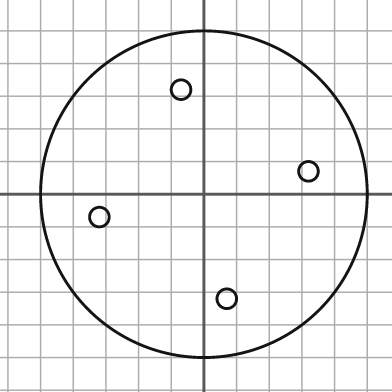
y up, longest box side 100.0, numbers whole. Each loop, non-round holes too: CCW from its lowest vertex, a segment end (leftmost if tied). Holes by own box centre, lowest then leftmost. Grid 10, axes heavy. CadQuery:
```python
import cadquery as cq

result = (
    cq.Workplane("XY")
    .moveTo(0.0, 0.0)
    .circle(50.0)
    .moveTo(7.0, -32.0)
    .circle(3.0)
    .moveTo(-32.0, -7.0)
    .circle(3.0)
    .moveTo(32.0, 7.0)
    .circle(3.0)
    .moveTo(-7.0, 32.0)
    .circle(3.0)
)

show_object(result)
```